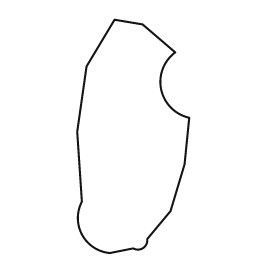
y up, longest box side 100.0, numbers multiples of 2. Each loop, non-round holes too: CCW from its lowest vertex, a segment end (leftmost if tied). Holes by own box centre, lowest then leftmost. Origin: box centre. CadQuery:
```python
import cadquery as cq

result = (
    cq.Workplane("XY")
    .moveTo(-10.0, -50.0)
    .lineTo(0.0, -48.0)
    .threePointArc((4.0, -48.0), (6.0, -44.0))
    .lineTo(16.0, -32.0)
    .lineTo(22.0, -12.0)
    .lineTo(24.0, 8.0)
    .threePointArc((12.0, 20.0), (18.0, 36.0))
    .lineTo(4.0, 48.0)
    .lineTo(-8.0, 50.0)
    .lineTo(-20.0, 30.0)
    .lineTo(-24.0, 2.0)
    .lineTo(-22.0, -28.0)
    .threePointArc((-22.0, -42.0), (-10.0, -50.0))
    .close()
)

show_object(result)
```